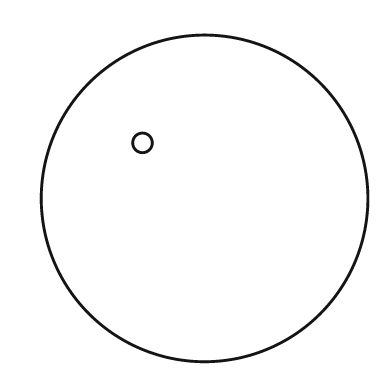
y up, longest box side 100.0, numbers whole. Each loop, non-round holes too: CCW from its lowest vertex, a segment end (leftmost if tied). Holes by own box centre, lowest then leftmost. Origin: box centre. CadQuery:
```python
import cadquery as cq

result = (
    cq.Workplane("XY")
    .moveTo(0.0, 0.0)
    .circle(50.0)
    .moveTo(-19.0, 17.0)
    .circle(3.0)
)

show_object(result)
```